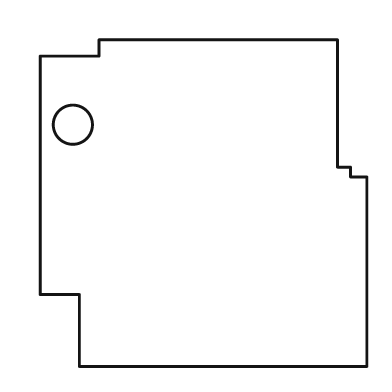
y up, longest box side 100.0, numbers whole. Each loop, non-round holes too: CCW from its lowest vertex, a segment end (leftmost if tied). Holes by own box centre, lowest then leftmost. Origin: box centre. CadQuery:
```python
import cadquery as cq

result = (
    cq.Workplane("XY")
    .moveTo(-38.0, -50.0)
    .lineTo(50.0, -50.0)
    .lineTo(50.0, 8.0)
    .lineTo(45.0, 8.0)
    .lineTo(45.0, 11.0)
    .lineTo(41.0, 11.0)
    .lineTo(41.0, 50.0)
    .lineTo(-32.0, 50.0)
    .lineTo(-32.0, 45.0)
    .lineTo(-50.0, 45.0)
    .lineTo(-50.0, -28.0)
    .lineTo(-38.0, -28.0)
    .close()
    .moveTo(-40.0, 24.0)
    .circle(6.0)
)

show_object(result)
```